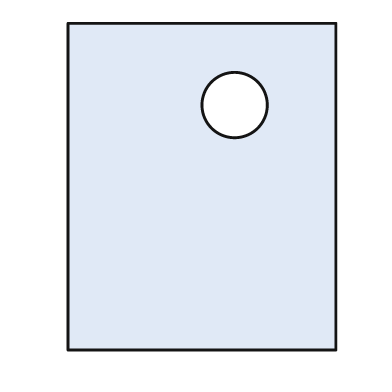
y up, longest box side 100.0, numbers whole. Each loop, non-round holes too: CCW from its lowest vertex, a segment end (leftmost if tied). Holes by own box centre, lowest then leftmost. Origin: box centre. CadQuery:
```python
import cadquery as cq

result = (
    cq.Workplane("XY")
    .moveTo(-41.0, -50.0)
    .lineTo(41.0, -50.0)
    .lineTo(41.0, 50.0)
    .lineTo(-41.0, 50.0)
    .close()
    .moveTo(10.0, 25.0)
    .circle(10.0)
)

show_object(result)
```